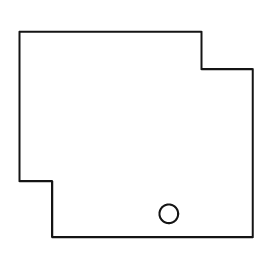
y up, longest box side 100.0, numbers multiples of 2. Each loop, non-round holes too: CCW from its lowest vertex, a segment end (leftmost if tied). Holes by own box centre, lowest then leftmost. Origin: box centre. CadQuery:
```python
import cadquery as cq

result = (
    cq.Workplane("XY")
    .moveTo(-36.0, -44.0)
    .lineTo(50.0, -44.0)
    .lineTo(50.0, 28.0)
    .lineTo(28.0, 28.0)
    .lineTo(28.0, 44.0)
    .lineTo(-50.0, 44.0)
    .lineTo(-50.0, -20.0)
    .lineTo(-36.0, -20.0)
    .close()
    .moveTo(14.0, -34.0)
    .circle(4.0)
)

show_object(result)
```